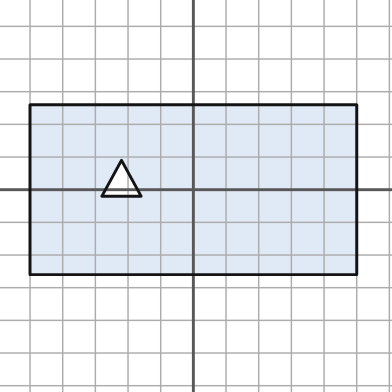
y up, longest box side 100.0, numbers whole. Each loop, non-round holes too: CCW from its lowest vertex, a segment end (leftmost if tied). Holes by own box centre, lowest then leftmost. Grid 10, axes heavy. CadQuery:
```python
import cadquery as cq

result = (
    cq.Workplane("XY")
    .moveTo(-50.0, -26.0)
    .lineTo(50.0, -26.0)
    .lineTo(50.0, 26.0)
    .lineTo(-50.0, 26.0)
    .close()
    .moveTo(-28.0, -2.0)
    .lineTo(-16.0, -2.0)
    .lineTo(-22.0, 9.0)
    .close()
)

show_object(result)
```